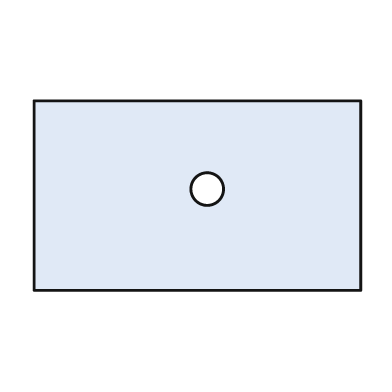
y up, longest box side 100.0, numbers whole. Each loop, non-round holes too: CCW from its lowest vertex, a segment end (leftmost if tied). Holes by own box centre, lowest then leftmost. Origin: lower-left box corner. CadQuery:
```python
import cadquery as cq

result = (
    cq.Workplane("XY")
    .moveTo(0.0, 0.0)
    .lineTo(100.0, 0.0)
    .lineTo(100.0, 58.0)
    .lineTo(0.0, 58.0)
    .close()
    .moveTo(53.0, 31.0)
    .circle(5.0)
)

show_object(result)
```